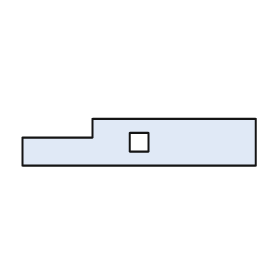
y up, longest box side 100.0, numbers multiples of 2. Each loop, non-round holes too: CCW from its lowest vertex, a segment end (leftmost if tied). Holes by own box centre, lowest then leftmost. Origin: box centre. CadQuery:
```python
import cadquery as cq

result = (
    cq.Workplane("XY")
    .moveTo(-50.0, -10.0)
    .lineTo(50.0, -10.0)
    .lineTo(50.0, 10.0)
    .lineTo(-20.0, 10.0)
    .lineTo(-20.0, 2.0)
    .lineTo(-50.0, 2.0)
    .close()
    .moveTo(-4.0, -4.0)
    .lineTo(4.0, -4.0)
    .lineTo(4.0, 4.0)
    .lineTo(-4.0, 4.0)
    .close()
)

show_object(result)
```